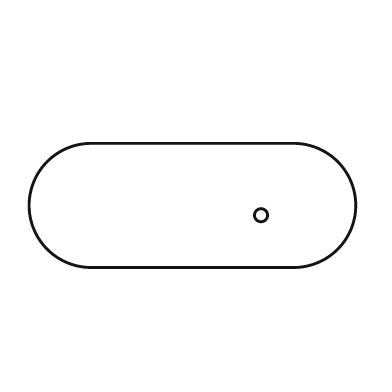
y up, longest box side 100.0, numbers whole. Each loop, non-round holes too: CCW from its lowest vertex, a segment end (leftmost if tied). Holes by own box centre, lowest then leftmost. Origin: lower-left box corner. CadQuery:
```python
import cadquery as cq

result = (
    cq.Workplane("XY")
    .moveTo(19.0, 0.0)
    .lineTo(81.0, 0.0)
    .threePointArc((100.0, 19.0), (81.0, 38.0))
    .lineTo(19.0, 38.0)
    .threePointArc((0.0, 19.0), (19.0, 0.0))
    .close()
    .moveTo(71.0, 16.0)
    .circle(2.0)
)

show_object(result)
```